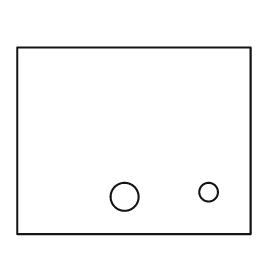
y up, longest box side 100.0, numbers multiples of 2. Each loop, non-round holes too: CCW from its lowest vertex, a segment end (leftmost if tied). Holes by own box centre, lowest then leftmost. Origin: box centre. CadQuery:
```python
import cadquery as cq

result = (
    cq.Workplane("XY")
    .moveTo(-50.0, -40.0)
    .lineTo(50.0, -40.0)
    .lineTo(50.0, 40.0)
    .lineTo(-50.0, 40.0)
    .close()
    .moveTo(-4.0, -24.0)
    .circle(6.0)
    .moveTo(32.0, -22.0)
    .circle(4.0)
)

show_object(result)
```